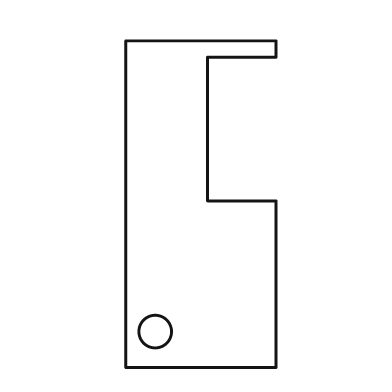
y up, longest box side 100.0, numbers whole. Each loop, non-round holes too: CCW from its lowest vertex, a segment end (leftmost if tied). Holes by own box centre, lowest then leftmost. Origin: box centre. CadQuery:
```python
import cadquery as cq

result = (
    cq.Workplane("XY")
    .moveTo(-23.0, -50.0)
    .lineTo(23.0, -50.0)
    .lineTo(23.0, 1.0)
    .lineTo(2.0, 1.0)
    .lineTo(2.0, 45.0)
    .lineTo(23.0, 45.0)
    .lineTo(23.0, 50.0)
    .lineTo(-23.0, 50.0)
    .close()
    .moveTo(-14.0, -39.0)
    .circle(5.0)
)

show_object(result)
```